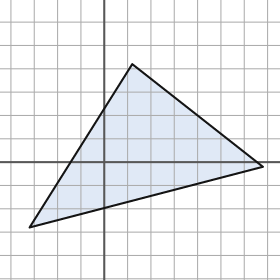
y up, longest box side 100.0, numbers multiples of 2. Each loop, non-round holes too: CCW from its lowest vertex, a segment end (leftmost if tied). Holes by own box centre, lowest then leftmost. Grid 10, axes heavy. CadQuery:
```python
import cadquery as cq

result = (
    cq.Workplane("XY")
    .moveTo(-32.0, -28.0)
    .lineTo(68.0, -2.0)
    .lineTo(12.0, 42.0)
    .close()
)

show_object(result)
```